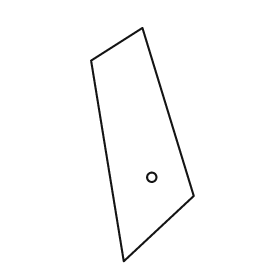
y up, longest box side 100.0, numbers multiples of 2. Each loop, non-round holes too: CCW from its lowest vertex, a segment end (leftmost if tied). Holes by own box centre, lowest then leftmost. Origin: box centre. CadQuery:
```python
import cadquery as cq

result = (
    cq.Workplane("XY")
    .moveTo(-8.0, -50.0)
    .lineTo(22.0, -22.0)
    .lineTo(0.0, 50.0)
    .lineTo(-22.0, 36.0)
    .close()
    .moveTo(4.0, -14.0)
    .circle(2.0)
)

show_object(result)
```